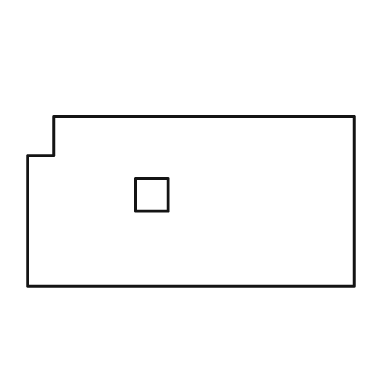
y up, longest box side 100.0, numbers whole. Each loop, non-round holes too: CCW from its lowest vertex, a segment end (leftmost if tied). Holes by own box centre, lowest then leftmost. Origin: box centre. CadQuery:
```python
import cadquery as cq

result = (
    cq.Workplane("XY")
    .moveTo(-50.0, -26.0)
    .lineTo(50.0, -26.0)
    .lineTo(50.0, 26.0)
    .lineTo(-42.0, 26.0)
    .lineTo(-42.0, 14.0)
    .lineTo(-50.0, 14.0)
    .close()
    .moveTo(-17.0, -3.0)
    .lineTo(-7.0, -3.0)
    .lineTo(-7.0, 7.0)
    .lineTo(-17.0, 7.0)
    .close()
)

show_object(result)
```